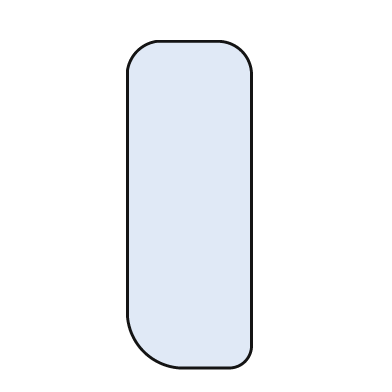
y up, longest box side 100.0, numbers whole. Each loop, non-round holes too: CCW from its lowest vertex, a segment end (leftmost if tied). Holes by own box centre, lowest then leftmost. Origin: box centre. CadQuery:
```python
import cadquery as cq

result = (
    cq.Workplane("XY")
    .moveTo(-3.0, -50.0)
    .lineTo(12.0, -50.0)
    .threePointArc((17.0, -48.0), (19.0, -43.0))
    .lineTo(19.0, 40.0)
    .threePointArc((16.0, 47.0), (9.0, 50.0))
    .lineTo(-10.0, 50.0)
    .threePointArc((-16.0, 47.0), (-19.0, 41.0))
    .lineTo(-19.0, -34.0)
    .threePointArc((-14.0, -45.0), (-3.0, -50.0))
    .close()
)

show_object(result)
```